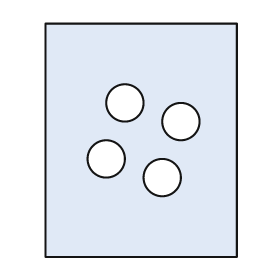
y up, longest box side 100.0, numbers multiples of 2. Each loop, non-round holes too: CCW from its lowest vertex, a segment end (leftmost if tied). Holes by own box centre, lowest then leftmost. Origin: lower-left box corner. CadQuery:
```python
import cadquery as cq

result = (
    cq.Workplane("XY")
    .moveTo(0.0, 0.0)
    .lineTo(82.0, 0.0)
    .lineTo(82.0, 100.0)
    .lineTo(0.0, 100.0)
    .close()
    .moveTo(50.0, 34.0)
    .circle(8.0)
    .moveTo(26.0, 42.0)
    .circle(8.0)
    .moveTo(58.0, 58.0)
    .circle(8.0)
    .moveTo(34.0, 66.0)
    .circle(8.0)
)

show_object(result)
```